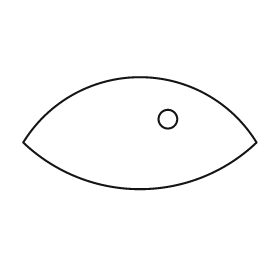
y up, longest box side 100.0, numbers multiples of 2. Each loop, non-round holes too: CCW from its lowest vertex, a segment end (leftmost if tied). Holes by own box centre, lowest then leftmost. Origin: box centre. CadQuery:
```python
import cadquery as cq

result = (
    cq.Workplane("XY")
    .moveTo(-50.0, -4.0)
    .threePointArc((0.0, -24.0), (50.0, -4.0))
    .threePointArc((0.0, 24.0), (-50.0, -4.0))
    .close()
    .moveTo(12.0, 6.0)
    .circle(4.0)
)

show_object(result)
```